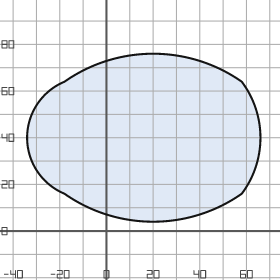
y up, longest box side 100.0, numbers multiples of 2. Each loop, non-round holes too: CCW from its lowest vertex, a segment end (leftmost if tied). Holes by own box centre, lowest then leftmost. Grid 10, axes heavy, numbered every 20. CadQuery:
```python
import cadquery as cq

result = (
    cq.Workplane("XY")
    .moveTo(-18.0, 16.0)
    .threePointArc((20.0, 4.0), (58.0, 16.0))
    .threePointArc((66.0, 40.0), (58.0, 64.0))
    .threePointArc((20.0, 76.0), (-18.0, 64.0))
    .threePointArc((-34.0, 40.0), (-18.0, 16.0))
    .close()
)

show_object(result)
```